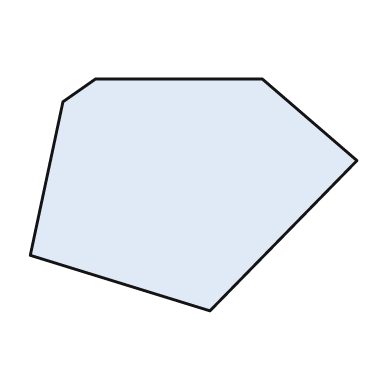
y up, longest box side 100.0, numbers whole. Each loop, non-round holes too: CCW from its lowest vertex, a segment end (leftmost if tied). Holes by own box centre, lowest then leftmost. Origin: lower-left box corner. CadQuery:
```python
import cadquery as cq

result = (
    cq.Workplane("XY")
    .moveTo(55.0, 0.0)
    .lineTo(100.0, 46.0)
    .lineTo(71.0, 71.0)
    .lineTo(20.0, 71.0)
    .lineTo(10.0, 64.0)
    .lineTo(0.0, 17.0)
    .close()
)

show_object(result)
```